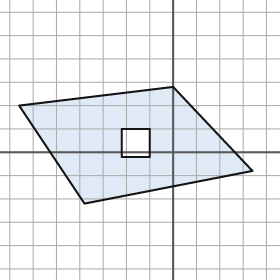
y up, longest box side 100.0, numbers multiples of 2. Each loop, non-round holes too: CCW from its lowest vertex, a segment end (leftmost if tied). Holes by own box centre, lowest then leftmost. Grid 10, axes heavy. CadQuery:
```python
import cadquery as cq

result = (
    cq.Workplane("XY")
    .moveTo(-38.0, -22.0)
    .lineTo(34.0, -8.0)
    .lineTo(0.0, 28.0)
    .lineTo(-66.0, 20.0)
    .close()
    .moveTo(-22.0, -2.0)
    .lineTo(-10.0, -2.0)
    .lineTo(-10.0, 10.0)
    .lineTo(-22.0, 10.0)
    .close()
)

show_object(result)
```